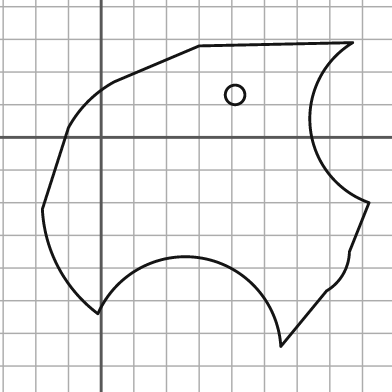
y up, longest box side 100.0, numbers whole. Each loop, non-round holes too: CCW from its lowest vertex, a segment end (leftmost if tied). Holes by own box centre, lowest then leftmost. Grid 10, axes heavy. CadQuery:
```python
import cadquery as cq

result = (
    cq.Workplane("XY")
    .moveTo(55.0, -64.0)
    .lineTo(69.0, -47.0)
    .threePointArc((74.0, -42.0), (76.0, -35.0))
    .lineTo(82.0, -20.0)
    .threePointArc((64.0, 3.0), (77.0, 29.0))
    .lineTo(30.0, 28.0)
    .lineTo(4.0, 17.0)
    .threePointArc((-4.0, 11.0), (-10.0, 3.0))
    .lineTo(-18.0, -22.0)
    .threePointArc((-13.0, -40.0), (-1.0, -54.0))
    .threePointArc((31.0, -37.0), (55.0, -64.0))
    .close()
    .moveTo(41.0, 13.0)
    .circle(3.0)
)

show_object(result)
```